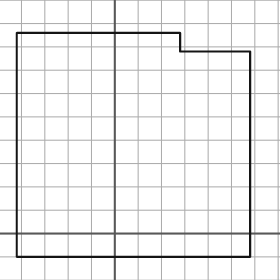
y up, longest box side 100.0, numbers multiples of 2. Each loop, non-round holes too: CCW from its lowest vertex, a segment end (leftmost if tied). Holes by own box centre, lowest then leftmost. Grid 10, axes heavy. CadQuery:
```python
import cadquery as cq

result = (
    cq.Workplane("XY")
    .moveTo(-42.0, -10.0)
    .lineTo(58.0, -10.0)
    .lineTo(58.0, 78.0)
    .lineTo(28.0, 78.0)
    .lineTo(28.0, 86.0)
    .lineTo(-42.0, 86.0)
    .close()
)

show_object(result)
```